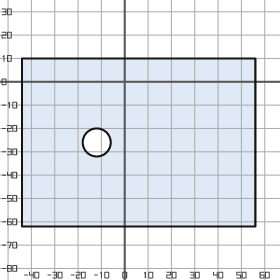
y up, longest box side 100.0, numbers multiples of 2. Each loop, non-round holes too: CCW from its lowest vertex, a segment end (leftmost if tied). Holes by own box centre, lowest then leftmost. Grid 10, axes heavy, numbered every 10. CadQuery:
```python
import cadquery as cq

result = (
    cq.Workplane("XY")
    .moveTo(-44.0, -62.0)
    .lineTo(56.0, -62.0)
    .lineTo(56.0, 10.0)
    .lineTo(-44.0, 10.0)
    .close()
    .moveTo(-12.0, -26.0)
    .circle(6.0)
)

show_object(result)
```